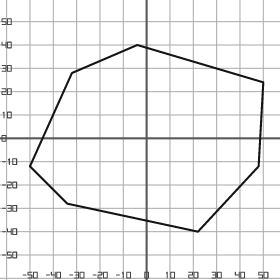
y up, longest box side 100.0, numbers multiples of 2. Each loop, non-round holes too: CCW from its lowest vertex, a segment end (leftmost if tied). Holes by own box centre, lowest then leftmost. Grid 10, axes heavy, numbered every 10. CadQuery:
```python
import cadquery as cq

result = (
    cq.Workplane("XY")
    .moveTo(22.0, -40.0)
    .lineTo(48.0, -12.0)
    .lineTo(50.0, 24.0)
    .lineTo(-4.0, 40.0)
    .lineTo(-32.0, 28.0)
    .lineTo(-50.0, -12.0)
    .lineTo(-34.0, -28.0)
    .close()
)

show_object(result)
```